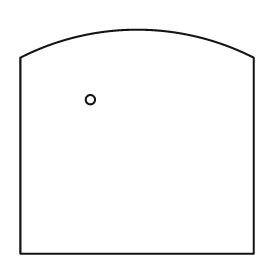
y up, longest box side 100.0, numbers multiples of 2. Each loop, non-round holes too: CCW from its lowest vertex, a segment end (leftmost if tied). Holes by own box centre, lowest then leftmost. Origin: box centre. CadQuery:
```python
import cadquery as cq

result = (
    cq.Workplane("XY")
    .moveTo(-50.0, -48.0)
    .lineTo(50.0, -48.0)
    .lineTo(50.0, 36.0)
    .threePointArc((0.0, 48.0), (-50.0, 36.0))
    .close()
    .moveTo(-20.0, 18.0)
    .circle(2.0)
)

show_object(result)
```